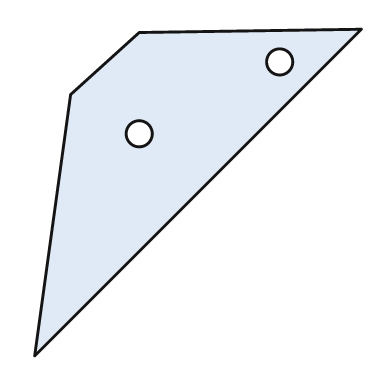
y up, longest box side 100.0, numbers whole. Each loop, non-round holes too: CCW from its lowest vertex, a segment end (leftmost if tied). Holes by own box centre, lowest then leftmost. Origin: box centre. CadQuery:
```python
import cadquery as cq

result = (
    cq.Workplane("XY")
    .moveTo(-50.0, -50.0)
    .lineTo(50.0, 50.0)
    .lineTo(-18.0, 49.0)
    .lineTo(-39.0, 30.0)
    .close()
    .moveTo(-18.0, 18.0)
    .circle(4.0)
    .moveTo(25.0, 40.0)
    .circle(4.0)
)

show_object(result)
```